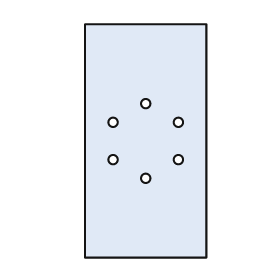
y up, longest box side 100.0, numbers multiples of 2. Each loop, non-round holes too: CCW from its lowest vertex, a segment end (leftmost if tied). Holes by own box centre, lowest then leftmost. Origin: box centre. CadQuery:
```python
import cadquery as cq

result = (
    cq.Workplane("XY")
    .moveTo(-26.0, -50.0)
    .lineTo(26.0, -50.0)
    .lineTo(26.0, 50.0)
    .lineTo(-26.0, 50.0)
    .close()
    .moveTo(0.0, -16.0)
    .circle(2.0)
    .moveTo(-14.0, -8.0)
    .circle(2.0)
    .moveTo(14.0, -8.0)
    .circle(2.0)
    .moveTo(-14.0, 8.0)
    .circle(2.0)
    .moveTo(14.0, 8.0)
    .circle(2.0)
    .moveTo(0.0, 16.0)
    .circle(2.0)
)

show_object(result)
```